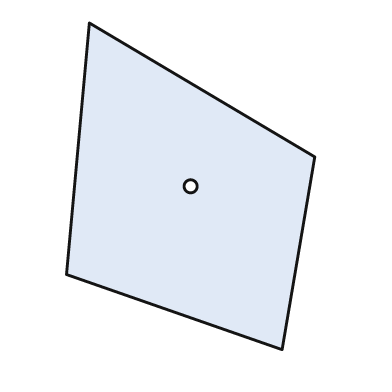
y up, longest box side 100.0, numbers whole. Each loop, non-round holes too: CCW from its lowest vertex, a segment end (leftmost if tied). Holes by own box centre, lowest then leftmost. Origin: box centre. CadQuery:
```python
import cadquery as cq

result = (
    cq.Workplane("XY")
    .moveTo(28.0, -50.0)
    .lineTo(38.0, 9.0)
    .lineTo(-31.0, 50.0)
    .lineTo(-38.0, -27.0)
    .close()
    .moveTo(0.0, 0.0)
    .circle(2.0)
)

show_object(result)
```